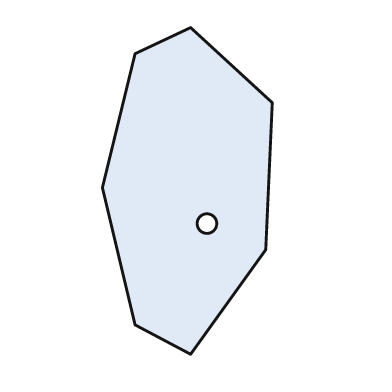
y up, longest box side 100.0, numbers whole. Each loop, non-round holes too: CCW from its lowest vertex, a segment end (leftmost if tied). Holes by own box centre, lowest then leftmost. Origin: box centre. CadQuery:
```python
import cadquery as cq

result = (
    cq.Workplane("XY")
    .moveTo(1.0, -50.0)
    .lineTo(24.0, -18.0)
    .lineTo(26.0, 27.0)
    .lineTo(1.0, 50.0)
    .lineTo(-16.0, 42.0)
    .lineTo(-26.0, 1.0)
    .lineTo(-16.0, -41.0)
    .close()
    .moveTo(6.0, -10.0)
    .circle(3.0)
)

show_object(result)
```